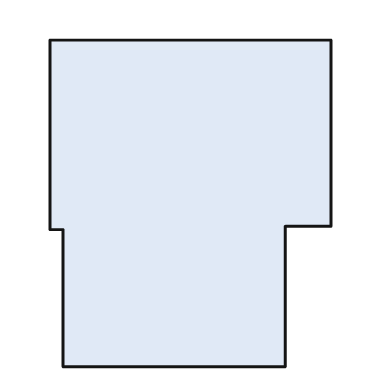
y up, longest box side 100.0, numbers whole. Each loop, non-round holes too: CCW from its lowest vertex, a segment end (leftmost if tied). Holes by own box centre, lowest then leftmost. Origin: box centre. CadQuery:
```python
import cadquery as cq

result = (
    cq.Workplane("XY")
    .moveTo(-39.0, -50.0)
    .lineTo(29.0, -50.0)
    .lineTo(29.0, -7.0)
    .lineTo(43.0, -7.0)
    .lineTo(43.0, 50.0)
    .lineTo(-43.0, 50.0)
    .lineTo(-43.0, -8.0)
    .lineTo(-39.0, -8.0)
    .close()
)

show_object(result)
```